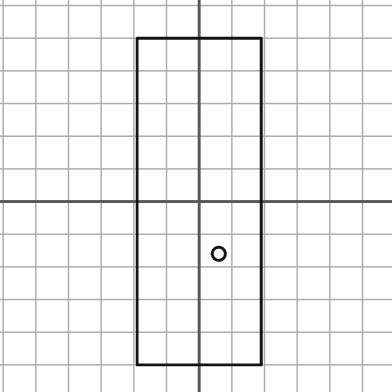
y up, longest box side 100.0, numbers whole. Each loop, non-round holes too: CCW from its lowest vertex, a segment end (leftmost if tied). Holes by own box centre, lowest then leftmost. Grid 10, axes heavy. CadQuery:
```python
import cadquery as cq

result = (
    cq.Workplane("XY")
    .moveTo(-19.0, -50.0)
    .lineTo(19.0, -50.0)
    .lineTo(19.0, 50.0)
    .lineTo(-19.0, 50.0)
    .close()
    .moveTo(6.0, -16.0)
    .circle(2.0)
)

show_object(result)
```